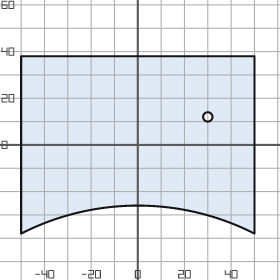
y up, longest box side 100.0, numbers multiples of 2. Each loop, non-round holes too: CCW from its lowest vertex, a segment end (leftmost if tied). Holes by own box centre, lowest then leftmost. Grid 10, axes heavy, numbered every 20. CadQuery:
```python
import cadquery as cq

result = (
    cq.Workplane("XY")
    .moveTo(-50.0, -38.0)
    .threePointArc((0.0, -26.0), (50.0, -38.0))
    .lineTo(50.0, 38.0)
    .lineTo(-50.0, 38.0)
    .close()
    .moveTo(30.0, 12.0)
    .circle(2.0)
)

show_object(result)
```